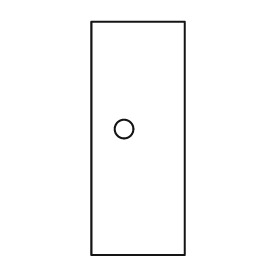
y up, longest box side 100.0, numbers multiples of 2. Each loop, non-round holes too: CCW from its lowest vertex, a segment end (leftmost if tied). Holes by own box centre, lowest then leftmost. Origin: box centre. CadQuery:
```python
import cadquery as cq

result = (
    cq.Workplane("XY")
    .moveTo(-20.0, -50.0)
    .lineTo(20.0, -50.0)
    .lineTo(20.0, 50.0)
    .lineTo(-20.0, 50.0)
    .close()
    .moveTo(-6.0, 4.0)
    .circle(4.0)
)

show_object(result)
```